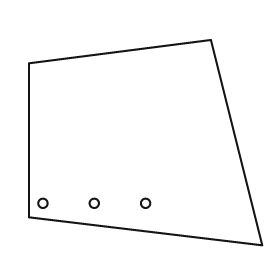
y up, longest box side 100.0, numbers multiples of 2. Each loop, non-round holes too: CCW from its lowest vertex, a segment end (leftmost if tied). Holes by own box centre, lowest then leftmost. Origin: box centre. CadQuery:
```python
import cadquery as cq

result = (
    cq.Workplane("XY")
    .moveTo(50.0, -44.0)
    .lineTo(28.0, 44.0)
    .lineTo(-50.0, 34.0)
    .lineTo(-50.0, -32.0)
    .close()
    .moveTo(-44.0, -26.0)
    .circle(2.0)
    .moveTo(-22.0, -26.0)
    .circle(2.0)
    .moveTo(0.0, -26.0)
    .circle(2.0)
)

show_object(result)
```